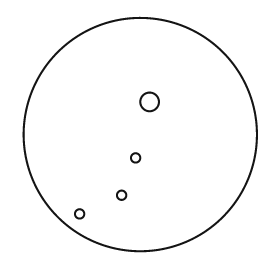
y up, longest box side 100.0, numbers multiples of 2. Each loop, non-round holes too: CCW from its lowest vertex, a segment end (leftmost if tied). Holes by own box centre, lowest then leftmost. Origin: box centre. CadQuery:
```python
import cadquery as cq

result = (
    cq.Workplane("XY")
    .moveTo(0.0, 0.0)
    .circle(50.0)
    .moveTo(-26.0, -34.0)
    .circle(2.0)
    .moveTo(-8.0, -26.0)
    .circle(2.0)
    .moveTo(-2.0, -10.0)
    .circle(2.0)
    .moveTo(4.0, 14.0)
    .circle(4.0)
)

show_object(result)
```